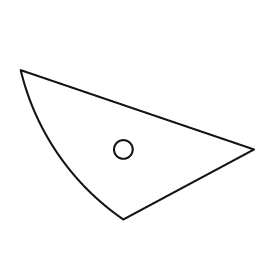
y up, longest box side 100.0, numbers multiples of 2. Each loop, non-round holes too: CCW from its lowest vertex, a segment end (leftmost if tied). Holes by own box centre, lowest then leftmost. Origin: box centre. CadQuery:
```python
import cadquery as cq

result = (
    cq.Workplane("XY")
    .moveTo(-6.0, -32.0)
    .lineTo(50.0, -2.0)
    .lineTo(-50.0, 32.0)
    .threePointArc((-34.0, -4.0), (-6.0, -32.0))
    .close()
    .moveTo(-6.0, -2.0)
    .circle(4.0)
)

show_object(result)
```